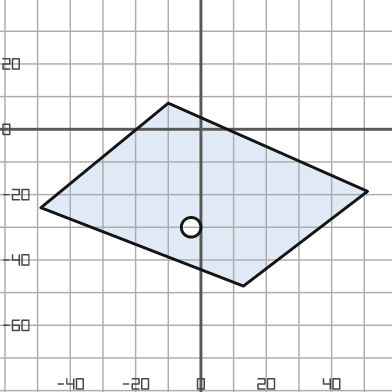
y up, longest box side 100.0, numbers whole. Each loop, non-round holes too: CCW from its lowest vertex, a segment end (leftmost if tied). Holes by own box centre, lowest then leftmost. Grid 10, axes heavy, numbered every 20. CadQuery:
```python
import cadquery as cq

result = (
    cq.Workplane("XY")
    .moveTo(13.0, -48.0)
    .lineTo(51.0, -19.0)
    .lineTo(-10.0, 8.0)
    .lineTo(-49.0, -24.0)
    .close()
    .moveTo(-3.0, -30.0)
    .circle(3.0)
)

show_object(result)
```